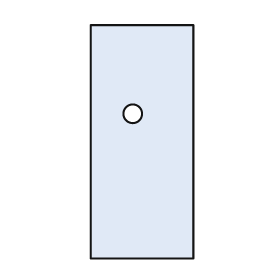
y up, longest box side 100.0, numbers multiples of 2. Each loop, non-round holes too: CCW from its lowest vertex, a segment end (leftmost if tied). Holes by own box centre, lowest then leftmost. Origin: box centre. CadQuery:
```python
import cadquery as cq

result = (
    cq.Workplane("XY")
    .moveTo(-22.0, -50.0)
    .lineTo(22.0, -50.0)
    .lineTo(22.0, 50.0)
    .lineTo(-22.0, 50.0)
    .close()
    .moveTo(-4.0, 12.0)
    .circle(4.0)
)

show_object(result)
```